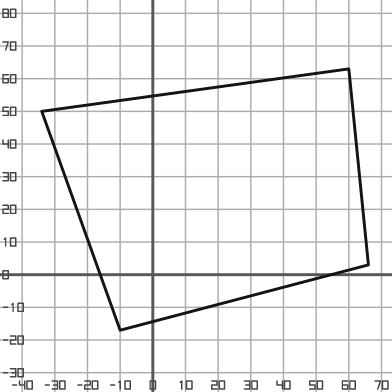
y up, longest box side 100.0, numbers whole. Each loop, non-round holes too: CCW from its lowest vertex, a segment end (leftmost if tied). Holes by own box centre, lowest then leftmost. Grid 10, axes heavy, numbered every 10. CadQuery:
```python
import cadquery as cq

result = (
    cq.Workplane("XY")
    .moveTo(-10.0, -17.0)
    .lineTo(66.0, 3.0)
    .lineTo(60.0, 63.0)
    .lineTo(-34.0, 50.0)
    .close()
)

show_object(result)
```